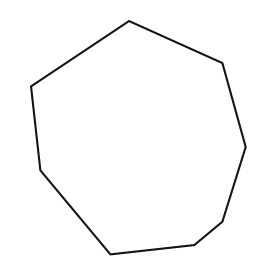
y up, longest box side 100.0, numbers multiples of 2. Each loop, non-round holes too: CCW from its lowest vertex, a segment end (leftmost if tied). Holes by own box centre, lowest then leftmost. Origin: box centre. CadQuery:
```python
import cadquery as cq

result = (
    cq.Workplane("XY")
    .moveTo(-12.0, -50.0)
    .lineTo(24.0, -46.0)
    .lineTo(36.0, -36.0)
    .lineTo(46.0, -4.0)
    .lineTo(36.0, 32.0)
    .lineTo(-4.0, 50.0)
    .lineTo(-46.0, 22.0)
    .lineTo(-42.0, -14.0)
    .close()
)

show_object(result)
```